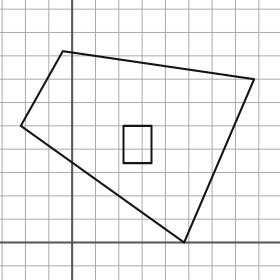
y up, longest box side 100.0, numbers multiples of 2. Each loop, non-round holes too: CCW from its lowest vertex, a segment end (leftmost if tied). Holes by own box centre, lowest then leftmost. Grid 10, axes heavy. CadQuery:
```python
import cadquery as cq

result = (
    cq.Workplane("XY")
    .moveTo(48.0, 0.0)
    .lineTo(78.0, 70.0)
    .lineTo(-4.0, 82.0)
    .lineTo(-22.0, 50.0)
    .close()
    .moveTo(22.0, 34.0)
    .lineTo(34.0, 34.0)
    .lineTo(34.0, 50.0)
    .lineTo(22.0, 50.0)
    .close()
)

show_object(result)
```